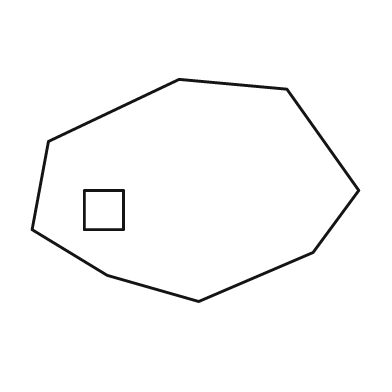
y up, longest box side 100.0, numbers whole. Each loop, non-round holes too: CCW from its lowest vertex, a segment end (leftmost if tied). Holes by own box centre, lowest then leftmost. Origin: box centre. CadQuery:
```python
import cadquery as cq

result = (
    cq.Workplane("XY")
    .moveTo(1.0, -34.0)
    .lineTo(36.0, -19.0)
    .lineTo(50.0, 0.0)
    .lineTo(28.0, 31.0)
    .lineTo(-5.0, 34.0)
    .lineTo(-45.0, 15.0)
    .lineTo(-50.0, -12.0)
    .lineTo(-27.0, -26.0)
    .close()
    .moveTo(-34.0, -12.0)
    .lineTo(-22.0, -12.0)
    .lineTo(-22.0, 0.0)
    .lineTo(-34.0, 0.0)
    .close()
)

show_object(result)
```